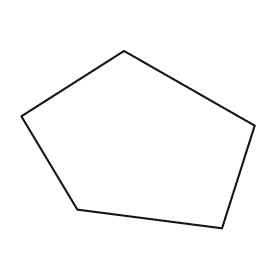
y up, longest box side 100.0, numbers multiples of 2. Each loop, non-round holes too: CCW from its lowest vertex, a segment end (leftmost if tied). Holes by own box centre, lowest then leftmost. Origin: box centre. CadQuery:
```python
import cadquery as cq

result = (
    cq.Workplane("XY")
    .moveTo(36.0, -38.0)
    .lineTo(50.0, 6.0)
    .lineTo(-6.0, 38.0)
    .lineTo(-50.0, 10.0)
    .lineTo(-26.0, -30.0)
    .close()
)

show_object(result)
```